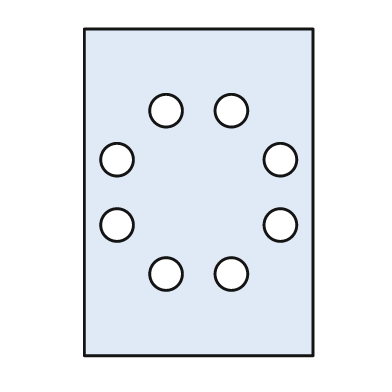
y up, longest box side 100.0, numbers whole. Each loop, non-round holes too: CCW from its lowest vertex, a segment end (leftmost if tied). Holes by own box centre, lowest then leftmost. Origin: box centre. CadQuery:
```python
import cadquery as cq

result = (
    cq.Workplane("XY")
    .moveTo(-35.0, -50.0)
    .lineTo(35.0, -50.0)
    .lineTo(35.0, 50.0)
    .lineTo(-35.0, 50.0)
    .close()
    .moveTo(-10.0, -25.0)
    .circle(5.0)
    .moveTo(10.0, -25.0)
    .circle(5.0)
    .moveTo(-25.0, -10.0)
    .circle(5.0)
    .moveTo(25.0, -10.0)
    .circle(5.0)
    .moveTo(-25.0, 10.0)
    .circle(5.0)
    .moveTo(25.0, 10.0)
    .circle(5.0)
    .moveTo(-10.0, 25.0)
    .circle(5.0)
    .moveTo(10.0, 25.0)
    .circle(5.0)
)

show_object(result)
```